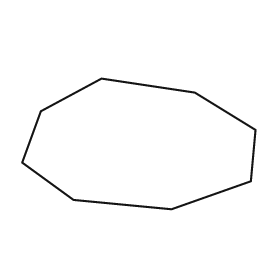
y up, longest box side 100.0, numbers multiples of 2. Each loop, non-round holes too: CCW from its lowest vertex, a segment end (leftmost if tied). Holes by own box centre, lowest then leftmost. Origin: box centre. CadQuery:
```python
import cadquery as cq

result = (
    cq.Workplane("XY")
    .moveTo(14.0, -28.0)
    .lineTo(48.0, -16.0)
    .lineTo(50.0, 6.0)
    .lineTo(24.0, 22.0)
    .lineTo(-16.0, 28.0)
    .lineTo(-42.0, 14.0)
    .lineTo(-50.0, -8.0)
    .lineTo(-28.0, -24.0)
    .close()
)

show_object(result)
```